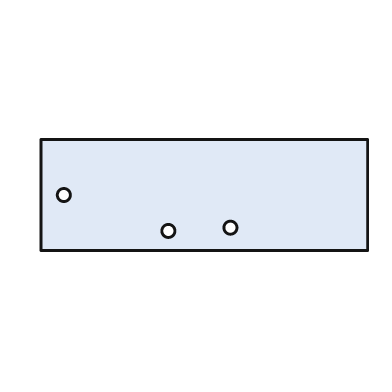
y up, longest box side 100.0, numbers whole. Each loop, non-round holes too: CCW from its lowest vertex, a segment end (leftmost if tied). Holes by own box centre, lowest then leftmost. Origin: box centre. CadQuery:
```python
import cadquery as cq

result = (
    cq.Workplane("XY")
    .moveTo(-50.0, -17.0)
    .lineTo(50.0, -17.0)
    .lineTo(50.0, 17.0)
    .lineTo(-50.0, 17.0)
    .close()
    .moveTo(-11.0, -11.0)
    .circle(2.0)
    .moveTo(8.0, -10.0)
    .circle(2.0)
    .moveTo(-43.0, 0.0)
    .circle(2.0)
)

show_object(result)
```